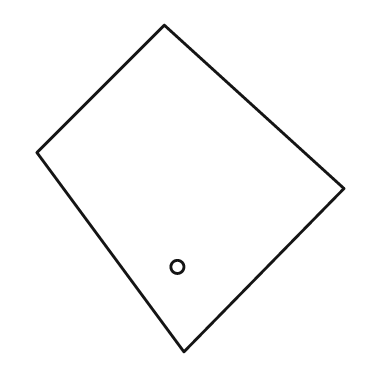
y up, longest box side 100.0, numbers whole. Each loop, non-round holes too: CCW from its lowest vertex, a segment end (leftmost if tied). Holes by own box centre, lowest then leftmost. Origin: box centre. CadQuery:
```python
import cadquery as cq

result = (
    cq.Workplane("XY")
    .moveTo(-2.0, -50.0)
    .lineTo(47.0, 0.0)
    .lineTo(-8.0, 50.0)
    .lineTo(-47.0, 11.0)
    .close()
    .moveTo(-4.0, -24.0)
    .circle(2.0)
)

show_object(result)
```